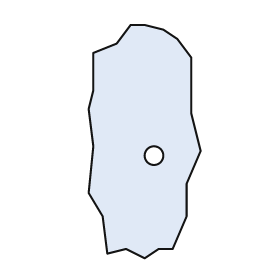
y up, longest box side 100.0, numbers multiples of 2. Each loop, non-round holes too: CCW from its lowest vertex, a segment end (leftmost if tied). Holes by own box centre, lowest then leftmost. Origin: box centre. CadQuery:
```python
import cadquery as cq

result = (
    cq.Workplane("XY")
    .moveTo(0.0, -50.0)
    .lineTo(6.0, -46.0)
    .lineTo(12.0, -46.0)
    .lineTo(18.0, -32.0)
    .lineTo(18.0, -18.0)
    .lineTo(24.0, -4.0)
    .lineTo(20.0, 12.0)
    .lineTo(20.0, 36.0)
    .lineTo(14.0, 44.0)
    .lineTo(8.0, 48.0)
    .lineTo(0.0, 50.0)
    .lineTo(-6.0, 50.0)
    .lineTo(-12.0, 42.0)
    .lineTo(-22.0, 38.0)
    .lineTo(-22.0, 22.0)
    .lineTo(-24.0, 14.0)
    .lineTo(-22.0, -2.0)
    .lineTo(-24.0, -22.0)
    .lineTo(-18.0, -32.0)
    .lineTo(-16.0, -48.0)
    .lineTo(-8.0, -46.0)
    .close()
    .moveTo(4.0, -6.0)
    .circle(4.0)
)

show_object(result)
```